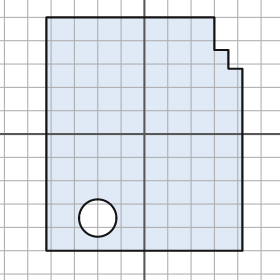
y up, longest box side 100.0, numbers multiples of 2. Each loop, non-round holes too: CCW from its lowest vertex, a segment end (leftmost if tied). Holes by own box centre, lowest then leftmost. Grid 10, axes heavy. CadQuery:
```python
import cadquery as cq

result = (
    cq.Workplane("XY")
    .moveTo(-42.0, -50.0)
    .lineTo(42.0, -50.0)
    .lineTo(42.0, 28.0)
    .lineTo(36.0, 28.0)
    .lineTo(36.0, 36.0)
    .lineTo(30.0, 36.0)
    .lineTo(30.0, 50.0)
    .lineTo(-42.0, 50.0)
    .close()
    .moveTo(-20.0, -36.0)
    .circle(8.0)
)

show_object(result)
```